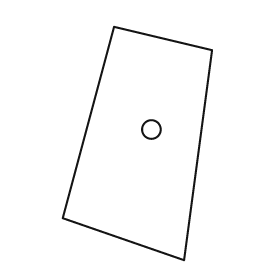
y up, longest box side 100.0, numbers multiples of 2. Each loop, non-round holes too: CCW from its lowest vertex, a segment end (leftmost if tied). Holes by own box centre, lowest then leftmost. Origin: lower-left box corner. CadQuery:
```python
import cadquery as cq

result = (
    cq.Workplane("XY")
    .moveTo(52.0, 0.0)
    .lineTo(64.0, 90.0)
    .lineTo(22.0, 100.0)
    .lineTo(0.0, 18.0)
    .close()
    .moveTo(38.0, 56.0)
    .circle(4.0)
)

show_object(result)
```